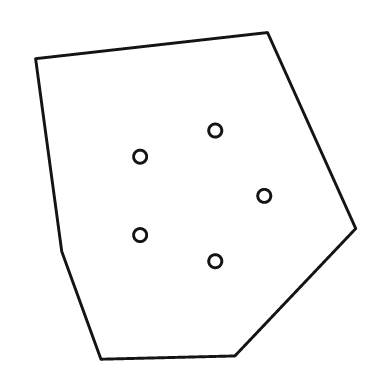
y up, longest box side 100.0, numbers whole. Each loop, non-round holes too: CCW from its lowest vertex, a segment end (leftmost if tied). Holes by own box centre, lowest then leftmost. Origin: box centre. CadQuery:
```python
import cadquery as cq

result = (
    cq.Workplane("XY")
    .moveTo(-29.0, -50.0)
    .lineTo(12.0, -49.0)
    .lineTo(49.0, -10.0)
    .lineTo(22.0, 50.0)
    .lineTo(-49.0, 42.0)
    .lineTo(-41.0, -17.0)
    .close()
    .moveTo(6.0, -20.0)
    .circle(2.0)
    .moveTo(-17.0, -12.0)
    .circle(2.0)
    .moveTo(21.0, 0.0)
    .circle(2.0)
    .moveTo(-17.0, 12.0)
    .circle(2.0)
    .moveTo(6.0, 20.0)
    .circle(2.0)
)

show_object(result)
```